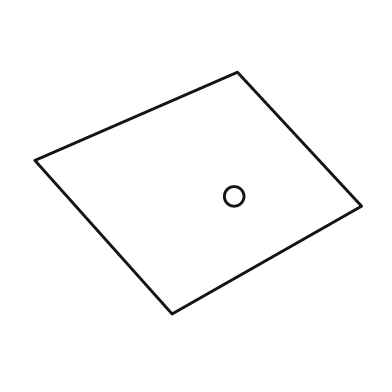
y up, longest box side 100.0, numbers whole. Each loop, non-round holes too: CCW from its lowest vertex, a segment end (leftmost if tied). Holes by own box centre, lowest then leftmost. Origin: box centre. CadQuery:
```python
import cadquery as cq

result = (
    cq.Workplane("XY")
    .moveTo(-8.0, -37.0)
    .lineTo(50.0, -4.0)
    .lineTo(12.0, 37.0)
    .lineTo(-50.0, 10.0)
    .close()
    .moveTo(11.0, -1.0)
    .circle(3.0)
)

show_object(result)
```